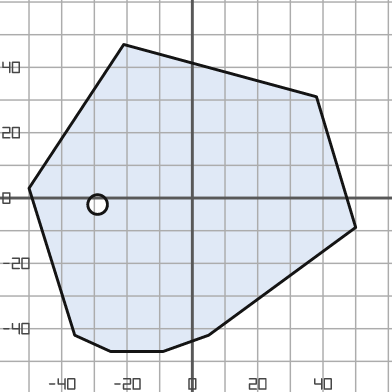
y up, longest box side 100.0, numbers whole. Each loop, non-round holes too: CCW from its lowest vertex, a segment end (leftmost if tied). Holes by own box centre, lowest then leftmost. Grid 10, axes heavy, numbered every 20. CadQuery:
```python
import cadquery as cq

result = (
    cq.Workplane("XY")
    .moveTo(-25.0, -47.0)
    .lineTo(-9.0, -47.0)
    .lineTo(5.0, -42.0)
    .lineTo(50.0, -9.0)
    .lineTo(38.0, 31.0)
    .lineTo(-21.0, 47.0)
    .lineTo(-50.0, 3.0)
    .lineTo(-36.0, -42.0)
    .close()
    .moveTo(-29.0, -2.0)
    .circle(3.0)
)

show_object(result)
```